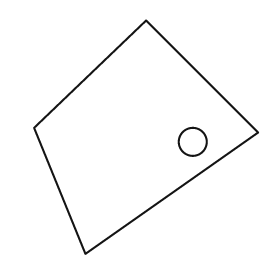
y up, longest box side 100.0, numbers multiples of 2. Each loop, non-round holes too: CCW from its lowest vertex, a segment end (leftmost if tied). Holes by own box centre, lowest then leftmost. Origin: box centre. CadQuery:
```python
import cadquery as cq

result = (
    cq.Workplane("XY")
    .moveTo(-26.0, -50.0)
    .lineTo(48.0, 2.0)
    .lineTo(0.0, 50.0)
    .lineTo(-48.0, 4.0)
    .close()
    .moveTo(20.0, -2.0)
    .circle(6.0)
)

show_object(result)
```